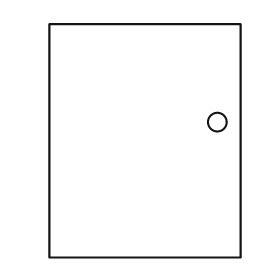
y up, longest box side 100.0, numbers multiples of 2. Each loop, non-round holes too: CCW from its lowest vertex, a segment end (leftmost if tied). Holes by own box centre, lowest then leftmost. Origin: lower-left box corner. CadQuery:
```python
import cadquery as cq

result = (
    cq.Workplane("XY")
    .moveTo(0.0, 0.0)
    .lineTo(82.0, 0.0)
    .lineTo(82.0, 100.0)
    .lineTo(0.0, 100.0)
    .close()
    .moveTo(72.0, 58.0)
    .circle(4.0)
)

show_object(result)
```